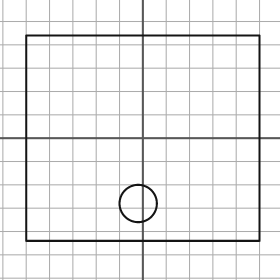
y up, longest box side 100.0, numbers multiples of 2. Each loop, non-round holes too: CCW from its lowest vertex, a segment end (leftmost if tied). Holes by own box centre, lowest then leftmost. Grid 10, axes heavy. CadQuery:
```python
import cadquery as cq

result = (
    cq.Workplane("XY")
    .moveTo(-50.0, -44.0)
    .lineTo(50.0, -44.0)
    .lineTo(50.0, 44.0)
    .lineTo(-50.0, 44.0)
    .close()
    .moveTo(-2.0, -28.0)
    .circle(8.0)
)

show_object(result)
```